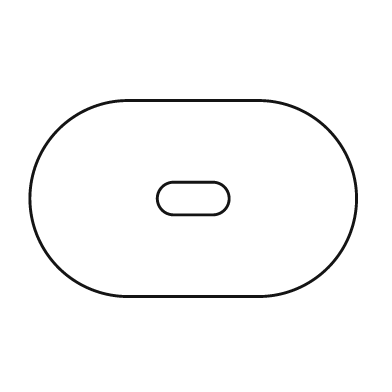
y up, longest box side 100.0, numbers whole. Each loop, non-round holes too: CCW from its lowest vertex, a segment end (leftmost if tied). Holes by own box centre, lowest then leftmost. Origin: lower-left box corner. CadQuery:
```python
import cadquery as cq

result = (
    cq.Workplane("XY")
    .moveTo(30.0, 0.0)
    .lineTo(70.0, 0.0)
    .threePointArc((100.0, 30.0), (70.0, 60.0))
    .lineTo(30.0, 60.0)
    .threePointArc((0.0, 30.0), (30.0, 0.0))
    .close()
    .moveTo(44.0, 25.0)
    .lineTo(56.0, 25.0)
    .threePointArc((61.0, 30.0), (56.0, 35.0))
    .lineTo(44.0, 35.0)
    .threePointArc((39.0, 30.0), (44.0, 25.0))
    .close()
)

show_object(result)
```